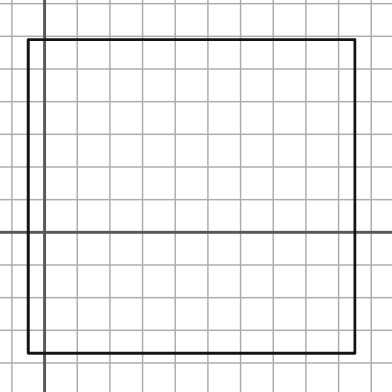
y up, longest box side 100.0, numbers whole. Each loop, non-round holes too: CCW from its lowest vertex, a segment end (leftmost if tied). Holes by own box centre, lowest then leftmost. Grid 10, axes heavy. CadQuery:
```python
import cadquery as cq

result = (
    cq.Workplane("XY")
    .moveTo(-5.0, -37.0)
    .lineTo(95.0, -37.0)
    .lineTo(95.0, 59.0)
    .lineTo(-5.0, 59.0)
    .close()
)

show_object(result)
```